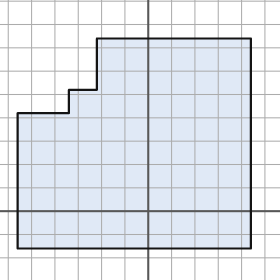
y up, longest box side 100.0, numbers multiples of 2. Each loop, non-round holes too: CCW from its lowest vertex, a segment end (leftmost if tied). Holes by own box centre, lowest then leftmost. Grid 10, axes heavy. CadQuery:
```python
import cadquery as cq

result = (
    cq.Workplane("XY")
    .moveTo(-56.0, -16.0)
    .lineTo(44.0, -16.0)
    .lineTo(44.0, 74.0)
    .lineTo(-22.0, 74.0)
    .lineTo(-22.0, 52.0)
    .lineTo(-34.0, 52.0)
    .lineTo(-34.0, 42.0)
    .lineTo(-56.0, 42.0)
    .close()
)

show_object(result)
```